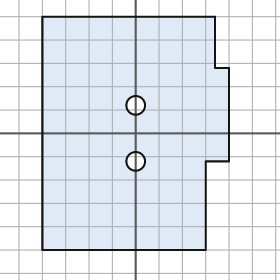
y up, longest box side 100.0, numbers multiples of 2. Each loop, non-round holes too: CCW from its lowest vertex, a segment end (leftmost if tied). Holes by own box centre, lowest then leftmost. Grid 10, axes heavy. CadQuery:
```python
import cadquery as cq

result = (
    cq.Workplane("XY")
    .moveTo(-40.0, -50.0)
    .lineTo(30.0, -50.0)
    .lineTo(30.0, -12.0)
    .lineTo(40.0, -12.0)
    .lineTo(40.0, 28.0)
    .lineTo(34.0, 28.0)
    .lineTo(34.0, 50.0)
    .lineTo(-40.0, 50.0)
    .close()
    .moveTo(0.0, -12.0)
    .circle(4.0)
    .moveTo(0.0, 12.0)
    .circle(4.0)
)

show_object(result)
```